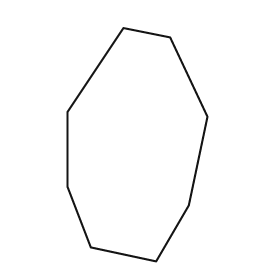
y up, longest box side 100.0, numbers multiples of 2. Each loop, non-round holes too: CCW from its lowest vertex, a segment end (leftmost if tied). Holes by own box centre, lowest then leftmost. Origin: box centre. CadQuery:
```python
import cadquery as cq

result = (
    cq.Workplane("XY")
    .moveTo(8.0, -50.0)
    .lineTo(22.0, -26.0)
    .lineTo(30.0, 12.0)
    .lineTo(14.0, 46.0)
    .lineTo(-6.0, 50.0)
    .lineTo(-30.0, 14.0)
    .lineTo(-30.0, -18.0)
    .lineTo(-20.0, -44.0)
    .close()
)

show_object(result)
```